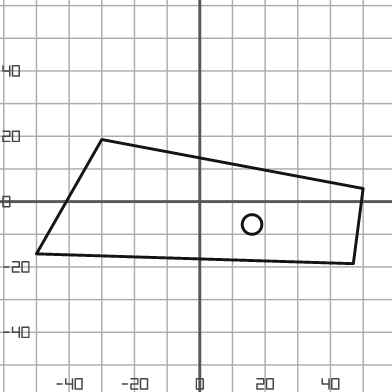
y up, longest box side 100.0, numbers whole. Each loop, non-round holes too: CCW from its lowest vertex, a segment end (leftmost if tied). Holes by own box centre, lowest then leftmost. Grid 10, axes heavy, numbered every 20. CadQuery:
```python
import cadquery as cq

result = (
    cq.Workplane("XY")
    .moveTo(47.0, -19.0)
    .lineTo(50.0, 4.0)
    .lineTo(-30.0, 19.0)
    .lineTo(-50.0, -16.0)
    .close()
    .moveTo(16.0, -7.0)
    .circle(3.0)
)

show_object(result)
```